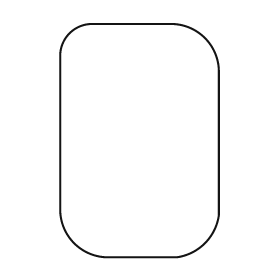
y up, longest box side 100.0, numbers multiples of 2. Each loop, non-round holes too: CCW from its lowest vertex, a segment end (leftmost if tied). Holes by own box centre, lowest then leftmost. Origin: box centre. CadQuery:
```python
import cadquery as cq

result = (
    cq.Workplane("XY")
    .moveTo(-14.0, -50.0)
    .lineTo(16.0, -50.0)
    .threePointArc((28.0, -44.0), (34.0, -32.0))
    .lineTo(34.0, 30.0)
    .threePointArc((28.0, 44.0), (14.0, 50.0))
    .lineTo(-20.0, 50.0)
    .threePointArc((-30.0, 46.0), (-34.0, 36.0))
    .lineTo(-34.0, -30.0)
    .threePointArc((-28.0, -44.0), (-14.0, -50.0))
    .close()
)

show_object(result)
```